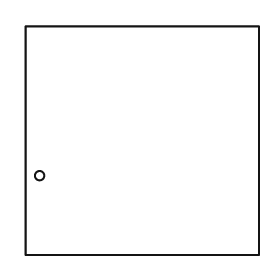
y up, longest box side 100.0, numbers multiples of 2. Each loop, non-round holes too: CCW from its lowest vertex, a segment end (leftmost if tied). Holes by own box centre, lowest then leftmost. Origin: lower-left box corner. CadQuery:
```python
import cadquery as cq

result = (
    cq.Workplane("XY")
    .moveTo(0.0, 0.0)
    .lineTo(100.0, 0.0)
    .lineTo(100.0, 98.0)
    .lineTo(0.0, 98.0)
    .close()
    .moveTo(6.0, 34.0)
    .circle(2.0)
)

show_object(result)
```